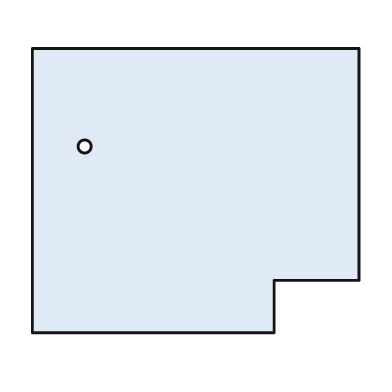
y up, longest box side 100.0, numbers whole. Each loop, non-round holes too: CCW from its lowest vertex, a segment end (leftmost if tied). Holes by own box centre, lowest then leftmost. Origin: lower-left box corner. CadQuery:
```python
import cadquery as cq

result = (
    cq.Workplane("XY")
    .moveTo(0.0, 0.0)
    .lineTo(74.0, 0.0)
    .lineTo(74.0, 16.0)
    .lineTo(100.0, 16.0)
    .lineTo(100.0, 87.0)
    .lineTo(0.0, 87.0)
    .close()
    .moveTo(16.0, 57.0)
    .circle(2.0)
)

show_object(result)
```